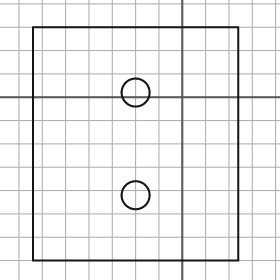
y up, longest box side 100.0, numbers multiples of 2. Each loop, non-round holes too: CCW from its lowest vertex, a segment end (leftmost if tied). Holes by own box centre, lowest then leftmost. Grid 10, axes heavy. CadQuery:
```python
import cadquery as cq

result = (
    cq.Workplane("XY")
    .moveTo(-64.0, -70.0)
    .lineTo(24.0, -70.0)
    .lineTo(24.0, 30.0)
    .lineTo(-64.0, 30.0)
    .close()
    .moveTo(-20.0, -42.0)
    .circle(6.0)
    .moveTo(-20.0, 2.0)
    .circle(6.0)
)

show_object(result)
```